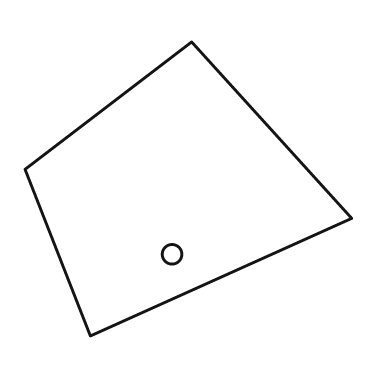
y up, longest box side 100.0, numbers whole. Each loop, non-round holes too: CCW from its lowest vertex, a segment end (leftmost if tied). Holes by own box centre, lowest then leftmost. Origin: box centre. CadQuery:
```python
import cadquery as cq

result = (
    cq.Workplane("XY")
    .moveTo(-30.0, -45.0)
    .lineTo(50.0, -9.0)
    .lineTo(1.0, 45.0)
    .lineTo(-50.0, 6.0)
    .close()
    .moveTo(-5.0, -20.0)
    .circle(3.0)
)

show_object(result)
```